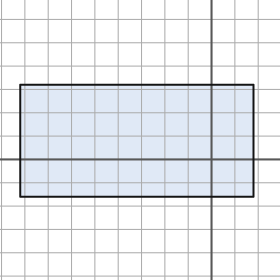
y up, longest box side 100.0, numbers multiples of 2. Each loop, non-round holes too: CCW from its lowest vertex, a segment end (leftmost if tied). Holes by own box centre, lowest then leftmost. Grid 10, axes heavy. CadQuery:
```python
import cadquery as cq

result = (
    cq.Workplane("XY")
    .moveTo(-82.0, -16.0)
    .lineTo(18.0, -16.0)
    .lineTo(18.0, 32.0)
    .lineTo(-82.0, 32.0)
    .close()
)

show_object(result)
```